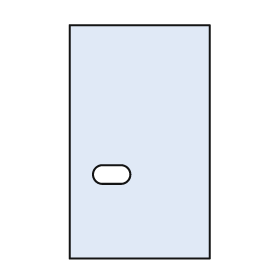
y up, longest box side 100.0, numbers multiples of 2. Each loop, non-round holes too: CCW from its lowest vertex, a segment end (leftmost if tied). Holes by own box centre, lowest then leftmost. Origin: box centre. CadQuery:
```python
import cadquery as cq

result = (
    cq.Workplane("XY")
    .moveTo(-30.0, -50.0)
    .lineTo(30.0, -50.0)
    .lineTo(30.0, 50.0)
    .lineTo(-30.0, 50.0)
    .close()
    .moveTo(-16.0, -18.0)
    .lineTo(-8.0, -18.0)
    .threePointArc((-4.0, -14.0), (-8.0, -10.0))
    .lineTo(-16.0, -10.0)
    .threePointArc((-20.0, -14.0), (-16.0, -18.0))
    .close()
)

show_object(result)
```